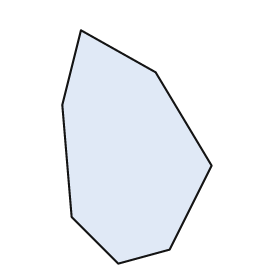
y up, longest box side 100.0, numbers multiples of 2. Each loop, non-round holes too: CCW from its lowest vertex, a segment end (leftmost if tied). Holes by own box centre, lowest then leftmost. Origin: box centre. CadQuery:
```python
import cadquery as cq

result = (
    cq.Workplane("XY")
    .moveTo(-8.0, -50.0)
    .lineTo(14.0, -44.0)
    .lineTo(32.0, -8.0)
    .lineTo(8.0, 32.0)
    .lineTo(-24.0, 50.0)
    .lineTo(-32.0, 18.0)
    .lineTo(-28.0, -30.0)
    .close()
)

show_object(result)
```